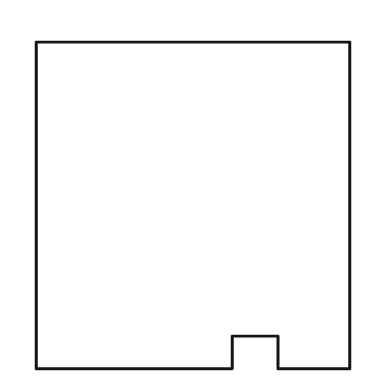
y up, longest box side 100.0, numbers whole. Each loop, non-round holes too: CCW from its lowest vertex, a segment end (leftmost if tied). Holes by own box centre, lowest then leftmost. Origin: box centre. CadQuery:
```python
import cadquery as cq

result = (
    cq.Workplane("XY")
    .moveTo(-48.0, -50.0)
    .lineTo(12.0, -50.0)
    .lineTo(12.0, -40.0)
    .lineTo(26.0, -40.0)
    .lineTo(26.0, -50.0)
    .lineTo(48.0, -50.0)
    .lineTo(48.0, 50.0)
    .lineTo(-48.0, 50.0)
    .close()
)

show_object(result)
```